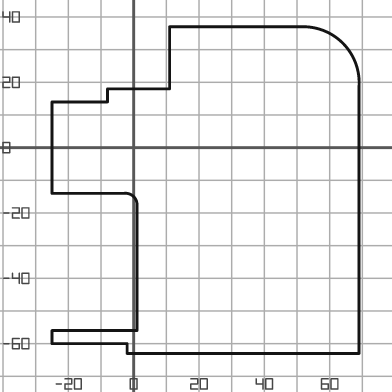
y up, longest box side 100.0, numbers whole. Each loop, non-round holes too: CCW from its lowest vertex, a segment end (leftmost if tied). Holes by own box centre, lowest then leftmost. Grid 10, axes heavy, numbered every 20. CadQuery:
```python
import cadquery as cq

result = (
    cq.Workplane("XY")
    .moveTo(-2.0, -63.0)
    .lineTo(69.0, -63.0)
    .lineTo(69.0, 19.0)
    .threePointArc((64.0, 32.0), (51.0, 37.0))
    .lineTo(11.0, 37.0)
    .lineTo(11.0, 18.0)
    .lineTo(-8.0, 18.0)
    .lineTo(-8.0, 14.0)
    .lineTo(-25.0, 14.0)
    .lineTo(-25.0, -14.0)
    .lineTo(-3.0, -14.0)
    .threePointArc((0.0, -15.0), (1.0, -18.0))
    .lineTo(1.0, -56.0)
    .lineTo(-25.0, -56.0)
    .lineTo(-25.0, -60.0)
    .lineTo(-2.0, -60.0)
    .close()
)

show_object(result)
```